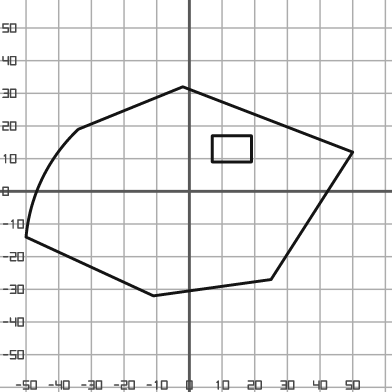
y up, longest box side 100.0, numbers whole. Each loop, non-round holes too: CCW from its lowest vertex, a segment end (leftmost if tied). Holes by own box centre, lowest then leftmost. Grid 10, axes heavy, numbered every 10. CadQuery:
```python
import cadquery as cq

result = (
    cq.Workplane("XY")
    .moveTo(-11.0, -32.0)
    .lineTo(25.0, -27.0)
    .lineTo(50.0, 12.0)
    .lineTo(-2.0, 32.0)
    .lineTo(-34.0, 19.0)
    .threePointArc((-45.0, 4.0), (-50.0, -14.0))
    .close()
    .moveTo(7.0, 9.0)
    .lineTo(19.0, 9.0)
    .lineTo(19.0, 17.0)
    .lineTo(7.0, 17.0)
    .close()
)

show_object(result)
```